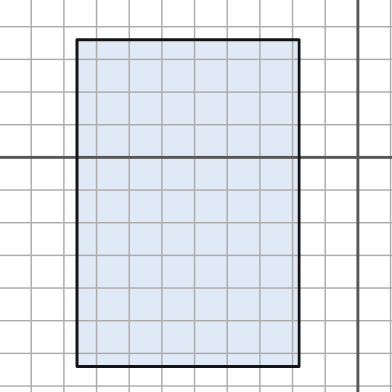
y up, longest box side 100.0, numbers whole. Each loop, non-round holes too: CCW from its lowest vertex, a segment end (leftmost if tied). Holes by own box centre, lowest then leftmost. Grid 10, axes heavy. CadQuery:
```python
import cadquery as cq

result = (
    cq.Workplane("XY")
    .moveTo(-86.0, -64.0)
    .lineTo(-18.0, -64.0)
    .lineTo(-18.0, 36.0)
    .lineTo(-86.0, 36.0)
    .close()
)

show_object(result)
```